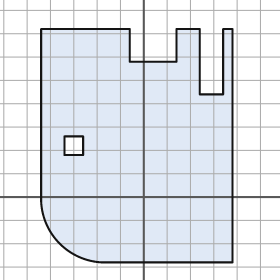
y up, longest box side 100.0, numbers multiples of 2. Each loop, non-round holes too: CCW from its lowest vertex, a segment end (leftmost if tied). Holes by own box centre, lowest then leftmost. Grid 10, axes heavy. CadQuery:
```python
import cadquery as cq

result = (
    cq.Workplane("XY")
    .moveTo(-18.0, -28.0)
    .lineTo(38.0, -28.0)
    .lineTo(38.0, 72.0)
    .lineTo(34.0, 72.0)
    .lineTo(34.0, 44.0)
    .lineTo(24.0, 44.0)
    .lineTo(24.0, 72.0)
    .lineTo(14.0, 72.0)
    .lineTo(14.0, 58.0)
    .lineTo(-6.0, 58.0)
    .lineTo(-6.0, 72.0)
    .lineTo(-44.0, 72.0)
    .lineTo(-44.0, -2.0)
    .threePointArc((-36.0, -20.0), (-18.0, -28.0))
    .close()
    .moveTo(-34.0, 18.0)
    .lineTo(-26.0, 18.0)
    .lineTo(-26.0, 26.0)
    .lineTo(-34.0, 26.0)
    .close()
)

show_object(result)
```